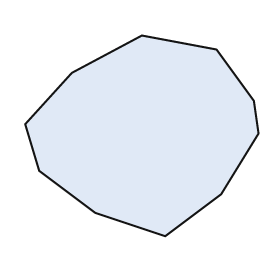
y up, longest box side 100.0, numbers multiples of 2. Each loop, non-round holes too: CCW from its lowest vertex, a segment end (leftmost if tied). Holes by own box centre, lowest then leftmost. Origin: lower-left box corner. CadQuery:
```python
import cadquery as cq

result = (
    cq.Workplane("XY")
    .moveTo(60.0, 0.0)
    .lineTo(84.0, 18.0)
    .lineTo(100.0, 44.0)
    .lineTo(98.0, 58.0)
    .lineTo(82.0, 80.0)
    .lineTo(50.0, 86.0)
    .lineTo(20.0, 70.0)
    .lineTo(0.0, 48.0)
    .lineTo(6.0, 28.0)
    .lineTo(30.0, 10.0)
    .close()
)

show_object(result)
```